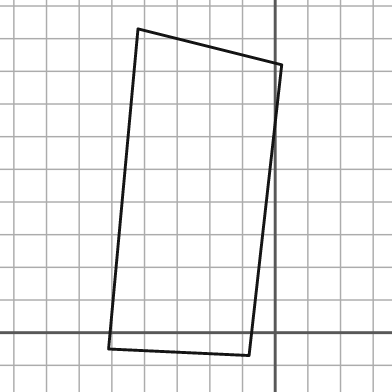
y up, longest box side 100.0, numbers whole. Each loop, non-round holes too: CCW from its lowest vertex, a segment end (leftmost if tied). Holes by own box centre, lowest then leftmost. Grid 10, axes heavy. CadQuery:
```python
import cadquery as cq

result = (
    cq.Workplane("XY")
    .moveTo(-8.0, -7.0)
    .lineTo(2.0, 82.0)
    .lineTo(-42.0, 93.0)
    .lineTo(-51.0, -5.0)
    .close()
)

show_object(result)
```